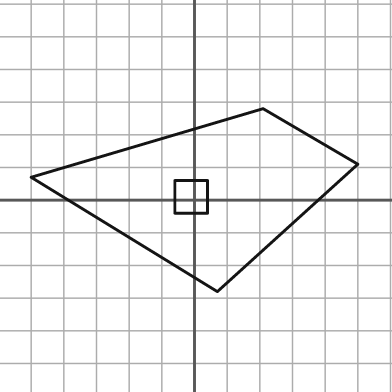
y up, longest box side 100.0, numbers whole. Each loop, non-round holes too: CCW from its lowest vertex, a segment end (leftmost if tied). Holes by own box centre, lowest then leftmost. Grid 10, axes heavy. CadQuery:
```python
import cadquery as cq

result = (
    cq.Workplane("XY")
    .moveTo(7.0, -28.0)
    .lineTo(50.0, 11.0)
    .lineTo(21.0, 28.0)
    .lineTo(-50.0, 7.0)
    .close()
    .moveTo(-6.0, -4.0)
    .lineTo(4.0, -4.0)
    .lineTo(4.0, 6.0)
    .lineTo(-6.0, 6.0)
    .close()
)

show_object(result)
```